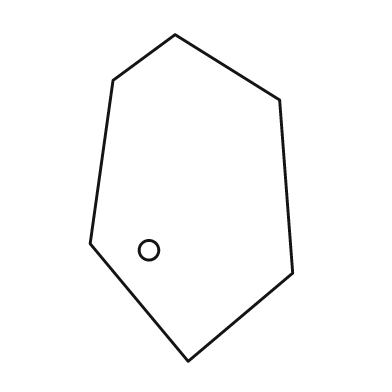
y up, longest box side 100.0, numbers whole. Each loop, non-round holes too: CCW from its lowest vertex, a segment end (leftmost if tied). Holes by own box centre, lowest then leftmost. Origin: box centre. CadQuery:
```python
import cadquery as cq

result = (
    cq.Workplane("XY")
    .moveTo(-1.0, -50.0)
    .lineTo(31.0, -23.0)
    .lineTo(27.0, 30.0)
    .lineTo(-5.0, 50.0)
    .lineTo(-24.0, 36.0)
    .lineTo(-31.0, -14.0)
    .close()
    .moveTo(-13.0, -16.0)
    .circle(3.0)
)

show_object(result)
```